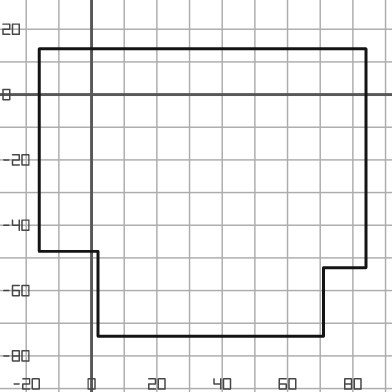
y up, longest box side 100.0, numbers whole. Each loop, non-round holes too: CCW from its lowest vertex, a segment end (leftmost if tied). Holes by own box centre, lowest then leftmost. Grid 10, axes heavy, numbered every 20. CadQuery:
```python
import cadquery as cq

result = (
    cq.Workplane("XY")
    .moveTo(2.0, -74.0)
    .lineTo(71.0, -74.0)
    .lineTo(71.0, -53.0)
    .lineTo(84.0, -53.0)
    .lineTo(84.0, 14.0)
    .lineTo(-16.0, 14.0)
    .lineTo(-16.0, -48.0)
    .lineTo(2.0, -48.0)
    .close()
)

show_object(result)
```